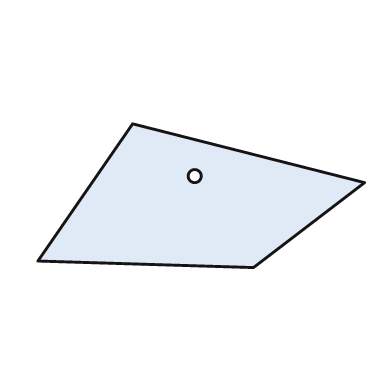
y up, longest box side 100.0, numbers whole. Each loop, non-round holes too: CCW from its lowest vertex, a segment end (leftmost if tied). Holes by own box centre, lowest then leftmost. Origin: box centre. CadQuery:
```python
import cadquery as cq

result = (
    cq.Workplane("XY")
    .moveTo(16.0, -22.0)
    .lineTo(50.0, 4.0)
    .lineTo(-21.0, 22.0)
    .lineTo(-50.0, -20.0)
    .close()
    .moveTo(-2.0, 6.0)
    .circle(2.0)
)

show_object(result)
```